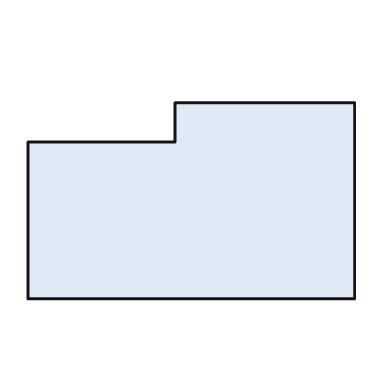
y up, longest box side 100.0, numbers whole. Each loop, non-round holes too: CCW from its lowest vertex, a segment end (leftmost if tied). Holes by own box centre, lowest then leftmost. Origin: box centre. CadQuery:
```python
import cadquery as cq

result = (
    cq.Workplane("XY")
    .moveTo(-50.0, -30.0)
    .lineTo(50.0, -30.0)
    .lineTo(50.0, 30.0)
    .lineTo(-5.0, 30.0)
    .lineTo(-5.0, 18.0)
    .lineTo(-50.0, 18.0)
    .close()
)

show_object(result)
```